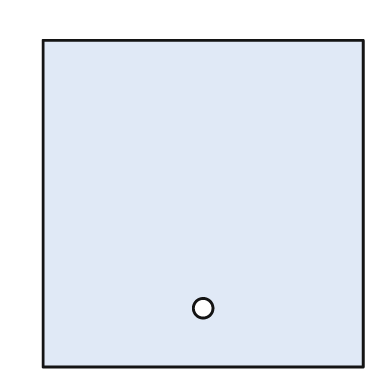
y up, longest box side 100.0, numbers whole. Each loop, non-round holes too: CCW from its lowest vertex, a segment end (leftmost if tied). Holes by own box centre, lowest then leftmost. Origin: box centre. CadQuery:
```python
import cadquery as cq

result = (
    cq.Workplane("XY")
    .moveTo(-49.0, -50.0)
    .lineTo(49.0, -50.0)
    .lineTo(49.0, 50.0)
    .lineTo(-49.0, 50.0)
    .close()
    .moveTo(0.0, -32.0)
    .circle(3.0)
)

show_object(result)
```